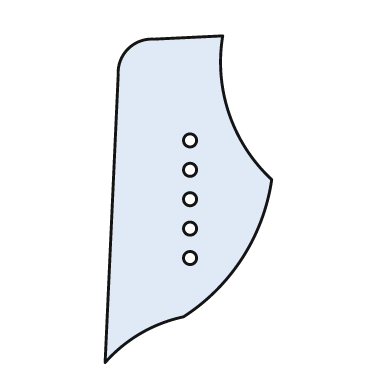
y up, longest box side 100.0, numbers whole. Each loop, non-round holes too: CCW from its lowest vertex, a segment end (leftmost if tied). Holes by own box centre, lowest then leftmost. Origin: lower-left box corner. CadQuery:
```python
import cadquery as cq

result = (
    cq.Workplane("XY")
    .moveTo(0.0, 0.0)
    .threePointArc((11.0, 9.0), (24.0, 14.0))
    .threePointArc((42.0, 32.0), (51.0, 56.0))
    .threePointArc((38.0, 76.0), (36.0, 100.0))
    .lineTo(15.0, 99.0)
    .threePointArc((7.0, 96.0), (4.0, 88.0))
    .close()
    .moveTo(26.0, 32.0)
    .circle(2.0)
    .moveTo(26.0, 41.0)
    .circle(2.0)
    .moveTo(26.0, 50.0)
    .circle(2.0)
    .moveTo(26.0, 59.0)
    .circle(2.0)
    .moveTo(26.0, 68.0)
    .circle(2.0)
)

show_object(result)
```